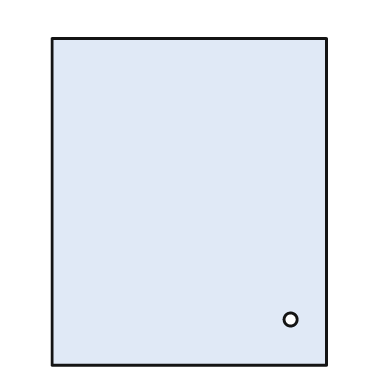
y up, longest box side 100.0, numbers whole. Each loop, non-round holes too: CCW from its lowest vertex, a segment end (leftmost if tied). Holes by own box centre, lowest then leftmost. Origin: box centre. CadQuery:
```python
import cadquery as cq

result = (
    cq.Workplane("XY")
    .moveTo(-42.0, -50.0)
    .lineTo(42.0, -50.0)
    .lineTo(42.0, 50.0)
    .lineTo(-42.0, 50.0)
    .close()
    .moveTo(31.0, -36.0)
    .circle(2.0)
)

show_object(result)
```